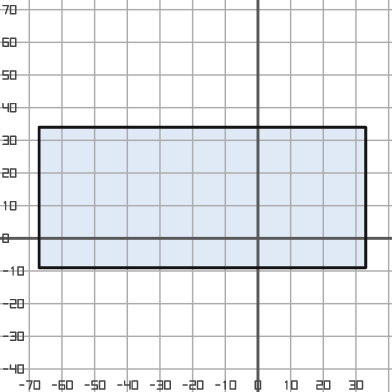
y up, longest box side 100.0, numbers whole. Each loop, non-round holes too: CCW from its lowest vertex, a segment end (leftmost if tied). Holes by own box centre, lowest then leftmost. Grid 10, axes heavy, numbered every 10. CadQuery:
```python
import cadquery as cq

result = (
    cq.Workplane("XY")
    .moveTo(-67.0, -9.0)
    .lineTo(33.0, -9.0)
    .lineTo(33.0, 34.0)
    .lineTo(-67.0, 34.0)
    .close()
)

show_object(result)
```